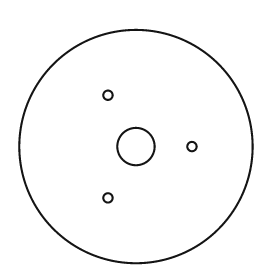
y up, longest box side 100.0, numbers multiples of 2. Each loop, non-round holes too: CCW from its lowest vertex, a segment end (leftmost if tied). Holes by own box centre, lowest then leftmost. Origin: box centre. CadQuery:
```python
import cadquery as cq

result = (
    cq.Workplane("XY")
    .moveTo(0.0, 0.0)
    .circle(50.0)
    .moveTo(-12.0, -22.0)
    .circle(2.0)
    .moveTo(0.0, 0.0)
    .circle(8.0)
    .moveTo(24.0, 0.0)
    .circle(2.0)
    .moveTo(-12.0, 22.0)
    .circle(2.0)
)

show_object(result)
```